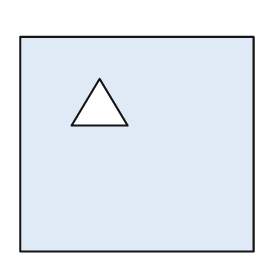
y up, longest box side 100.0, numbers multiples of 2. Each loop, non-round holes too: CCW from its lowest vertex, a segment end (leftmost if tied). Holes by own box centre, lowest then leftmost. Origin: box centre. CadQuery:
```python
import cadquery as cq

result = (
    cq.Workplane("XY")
    .moveTo(-50.0, -46.0)
    .lineTo(50.0, -46.0)
    .lineTo(50.0, 46.0)
    .lineTo(-50.0, 46.0)
    .close()
    .moveTo(-28.0, 8.0)
    .lineTo(-4.0, 8.0)
    .lineTo(-16.0, 28.0)
    .close()
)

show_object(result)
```